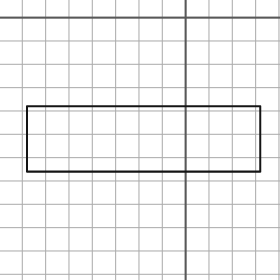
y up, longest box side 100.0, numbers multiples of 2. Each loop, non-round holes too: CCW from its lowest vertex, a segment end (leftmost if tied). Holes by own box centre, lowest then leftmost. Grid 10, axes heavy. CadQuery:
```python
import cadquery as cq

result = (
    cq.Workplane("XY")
    .moveTo(-68.0, -66.0)
    .lineTo(32.0, -66.0)
    .lineTo(32.0, -38.0)
    .lineTo(-68.0, -38.0)
    .close()
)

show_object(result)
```